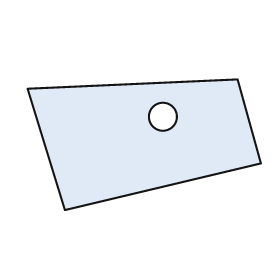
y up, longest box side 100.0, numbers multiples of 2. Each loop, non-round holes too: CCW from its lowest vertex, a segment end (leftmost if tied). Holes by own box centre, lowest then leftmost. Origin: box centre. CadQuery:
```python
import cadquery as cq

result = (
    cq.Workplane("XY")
    .moveTo(-34.0, -28.0)
    .lineTo(50.0, -8.0)
    .lineTo(40.0, 28.0)
    .lineTo(-50.0, 24.0)
    .close()
    .moveTo(8.0, 12.0)
    .circle(6.0)
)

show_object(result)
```